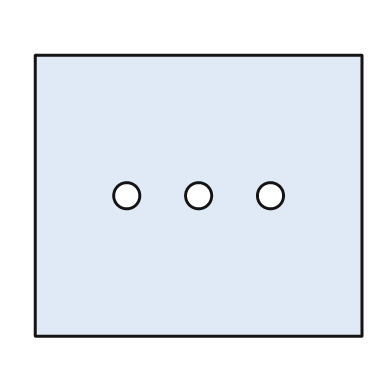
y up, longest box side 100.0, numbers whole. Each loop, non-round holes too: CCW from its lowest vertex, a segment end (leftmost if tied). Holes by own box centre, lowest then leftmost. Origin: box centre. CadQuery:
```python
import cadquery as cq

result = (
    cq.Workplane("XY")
    .moveTo(-50.0, -43.0)
    .lineTo(50.0, -43.0)
    .lineTo(50.0, 43.0)
    .lineTo(-50.0, 43.0)
    .close()
    .moveTo(-22.0, 0.0)
    .circle(4.0)
    .moveTo(0.0, 0.0)
    .circle(4.0)
    .moveTo(22.0, 0.0)
    .circle(4.0)
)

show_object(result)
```